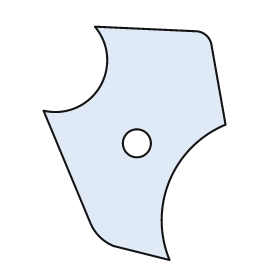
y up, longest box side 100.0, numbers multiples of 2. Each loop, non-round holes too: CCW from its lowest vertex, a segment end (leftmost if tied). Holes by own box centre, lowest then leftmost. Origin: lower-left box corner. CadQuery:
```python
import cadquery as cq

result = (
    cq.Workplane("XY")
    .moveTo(54.0, 0.0)
    .threePointArc((54.0, 34.0), (78.0, 58.0))
    .lineTo(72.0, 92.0)
    .threePointArc((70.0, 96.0), (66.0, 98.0))
    .lineTo(22.0, 100.0)
    .threePointArc((24.0, 74.0), (0.0, 64.0))
    .lineTo(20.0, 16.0)
    .threePointArc((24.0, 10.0), (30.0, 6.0))
    .close()
    .moveTo(40.0, 50.0)
    .circle(6.0)
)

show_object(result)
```